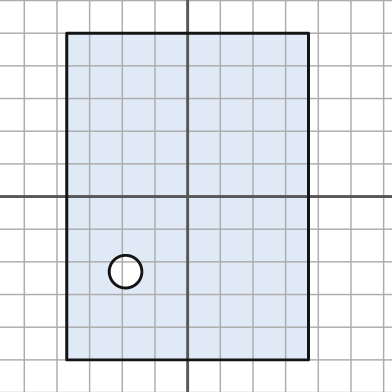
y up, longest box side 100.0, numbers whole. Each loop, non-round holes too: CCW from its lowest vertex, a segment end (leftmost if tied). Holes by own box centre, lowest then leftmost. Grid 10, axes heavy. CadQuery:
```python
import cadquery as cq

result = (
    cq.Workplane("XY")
    .moveTo(-37.0, -50.0)
    .lineTo(37.0, -50.0)
    .lineTo(37.0, 50.0)
    .lineTo(-37.0, 50.0)
    .close()
    .moveTo(-19.0, -23.0)
    .circle(5.0)
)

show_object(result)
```